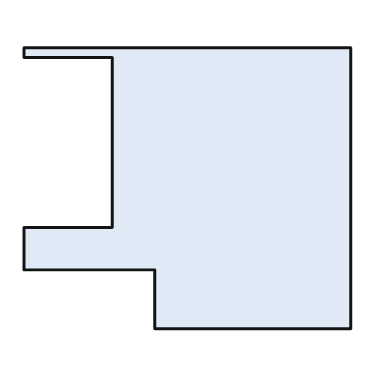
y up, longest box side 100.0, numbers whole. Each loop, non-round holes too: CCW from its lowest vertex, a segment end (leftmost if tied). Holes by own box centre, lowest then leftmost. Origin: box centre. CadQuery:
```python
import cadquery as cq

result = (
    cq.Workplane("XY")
    .moveTo(-10.0, -43.0)
    .lineTo(50.0, -43.0)
    .lineTo(50.0, 43.0)
    .lineTo(-50.0, 43.0)
    .lineTo(-50.0, 40.0)
    .lineTo(-23.0, 40.0)
    .lineTo(-23.0, -12.0)
    .lineTo(-50.0, -12.0)
    .lineTo(-50.0, -25.0)
    .lineTo(-10.0, -25.0)
    .close()
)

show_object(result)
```